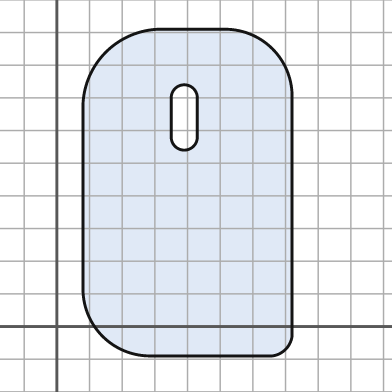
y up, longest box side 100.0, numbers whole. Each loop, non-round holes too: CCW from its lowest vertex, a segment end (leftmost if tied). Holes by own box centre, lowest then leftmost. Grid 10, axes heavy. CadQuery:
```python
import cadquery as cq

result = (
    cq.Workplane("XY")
    .moveTo(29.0, -9.0)
    .lineTo(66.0, -9.0)
    .threePointArc((70.0, -7.0), (72.0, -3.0))
    .lineTo(72.0, 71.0)
    .threePointArc((66.0, 85.0), (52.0, 91.0))
    .lineTo(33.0, 91.0)
    .threePointArc((15.0, 84.0), (8.0, 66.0))
    .lineTo(8.0, 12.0)
    .threePointArc((14.0, -3.0), (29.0, -9.0))
    .close()
    .moveTo(35.0, 58.0)
    .threePointArc((39.0, 54.0), (43.0, 58.0))
    .lineTo(43.0, 70.0)
    .threePointArc((39.0, 74.0), (35.0, 70.0))
    .close()
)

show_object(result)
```